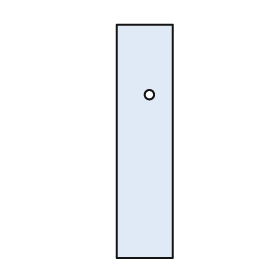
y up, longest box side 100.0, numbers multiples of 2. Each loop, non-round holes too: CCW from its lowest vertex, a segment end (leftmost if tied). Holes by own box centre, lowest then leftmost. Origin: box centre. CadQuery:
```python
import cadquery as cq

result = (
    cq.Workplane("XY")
    .moveTo(-12.0, -50.0)
    .lineTo(12.0, -50.0)
    .lineTo(12.0, 50.0)
    .lineTo(-12.0, 50.0)
    .close()
    .moveTo(2.0, 20.0)
    .circle(2.0)
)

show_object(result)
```